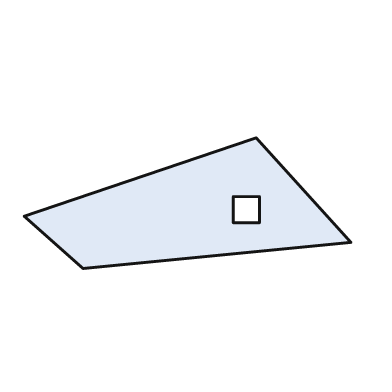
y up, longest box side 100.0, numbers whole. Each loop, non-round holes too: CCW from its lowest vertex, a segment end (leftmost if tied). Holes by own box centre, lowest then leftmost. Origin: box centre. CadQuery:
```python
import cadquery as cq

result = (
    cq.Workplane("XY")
    .moveTo(-32.0, -20.0)
    .lineTo(50.0, -12.0)
    .lineTo(21.0, 20.0)
    .lineTo(-50.0, -4.0)
    .close()
    .moveTo(14.0, -6.0)
    .lineTo(22.0, -6.0)
    .lineTo(22.0, 2.0)
    .lineTo(14.0, 2.0)
    .close()
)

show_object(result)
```